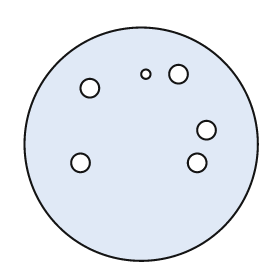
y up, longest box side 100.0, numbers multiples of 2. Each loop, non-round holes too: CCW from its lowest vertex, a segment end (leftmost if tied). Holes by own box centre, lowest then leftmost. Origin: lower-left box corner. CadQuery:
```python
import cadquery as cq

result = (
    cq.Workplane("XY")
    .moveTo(50.0, 50.0)
    .circle(50.0)
    .moveTo(24.0, 42.0)
    .circle(4.0)
    .moveTo(74.0, 42.0)
    .circle(4.0)
    .moveTo(78.0, 56.0)
    .circle(4.0)
    .moveTo(28.0, 74.0)
    .circle(4.0)
    .moveTo(52.0, 80.0)
    .circle(2.0)
    .moveTo(66.0, 80.0)
    .circle(4.0)
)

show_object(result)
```